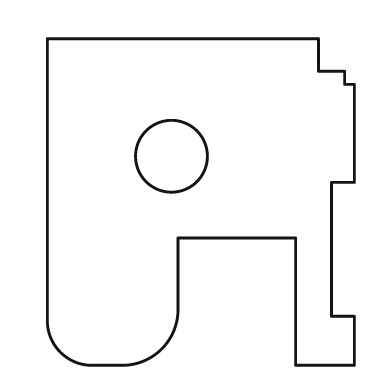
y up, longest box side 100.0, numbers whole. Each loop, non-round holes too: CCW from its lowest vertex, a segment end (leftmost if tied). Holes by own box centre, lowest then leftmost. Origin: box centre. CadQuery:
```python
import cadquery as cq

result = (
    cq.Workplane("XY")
    .moveTo(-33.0, -50.0)
    .lineTo(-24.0, -50.0)
    .threePointArc((-12.0, -45.0), (-7.0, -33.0))
    .lineTo(-7.0, -11.0)
    .lineTo(29.0, -11.0)
    .lineTo(29.0, -50.0)
    .lineTo(47.0, -50.0)
    .lineTo(47.0, -35.0)
    .lineTo(40.0, -35.0)
    .lineTo(40.0, 6.0)
    .lineTo(47.0, 6.0)
    .lineTo(47.0, 36.0)
    .lineTo(44.0, 36.0)
    .lineTo(44.0, 40.0)
    .lineTo(36.0, 40.0)
    .lineTo(36.0, 50.0)
    .lineTo(-47.0, 50.0)
    .lineTo(-47.0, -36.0)
    .threePointArc((-43.0, -46.0), (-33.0, -50.0))
    .close()
    .moveTo(-9.0, 14.0)
    .circle(11.0)
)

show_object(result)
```